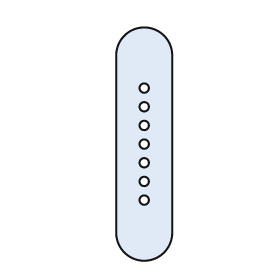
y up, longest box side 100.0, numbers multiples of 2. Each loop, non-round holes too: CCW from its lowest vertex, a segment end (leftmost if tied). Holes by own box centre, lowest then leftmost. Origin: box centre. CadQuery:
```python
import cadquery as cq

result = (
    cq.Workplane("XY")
    .moveTo(-12.0, -38.0)
    .threePointArc((0.0, -50.0), (12.0, -38.0))
    .lineTo(12.0, 38.0)
    .threePointArc((0.0, 50.0), (-12.0, 38.0))
    .close()
    .moveTo(0.0, -24.0)
    .circle(2.0)
    .moveTo(0.0, -16.0)
    .circle(2.0)
    .moveTo(0.0, -8.0)
    .circle(2.0)
    .moveTo(0.0, 0.0)
    .circle(2.0)
    .moveTo(0.0, 8.0)
    .circle(2.0)
    .moveTo(0.0, 16.0)
    .circle(2.0)
    .moveTo(0.0, 24.0)
    .circle(2.0)
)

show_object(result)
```